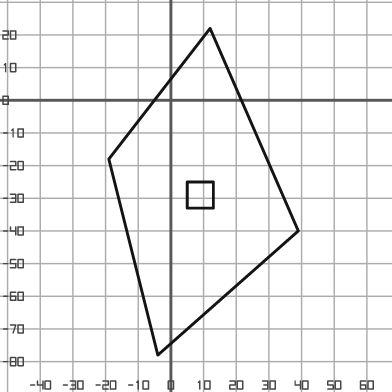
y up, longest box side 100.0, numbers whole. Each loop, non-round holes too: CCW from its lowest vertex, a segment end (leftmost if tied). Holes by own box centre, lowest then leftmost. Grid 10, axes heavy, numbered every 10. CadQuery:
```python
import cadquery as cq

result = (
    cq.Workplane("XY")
    .moveTo(-4.0, -78.0)
    .lineTo(39.0, -40.0)
    .lineTo(12.0, 22.0)
    .lineTo(-19.0, -18.0)
    .close()
    .moveTo(5.0, -33.0)
    .lineTo(13.0, -33.0)
    .lineTo(13.0, -25.0)
    .lineTo(5.0, -25.0)
    .close()
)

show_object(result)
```